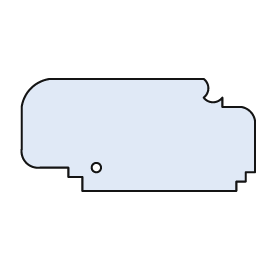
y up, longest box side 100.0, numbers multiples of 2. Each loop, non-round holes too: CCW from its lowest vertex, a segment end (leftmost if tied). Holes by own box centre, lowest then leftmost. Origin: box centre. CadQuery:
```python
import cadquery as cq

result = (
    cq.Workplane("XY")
    .moveTo(-24.0, -24.0)
    .lineTo(42.0, -24.0)
    .lineTo(42.0, -20.0)
    .lineTo(46.0, -20.0)
    .lineTo(46.0, -16.0)
    .lineTo(50.0, -16.0)
    .lineTo(50.0, 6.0)
    .threePointArc((48.0, 10.0), (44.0, 12.0))
    .lineTo(36.0, 12.0)
    .lineTo(36.0, 16.0)
    .threePointArc((32.0, 14.0), (28.0, 16.0))
    .threePointArc((30.0, 20.0), (28.0, 24.0))
    .lineTo(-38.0, 24.0)
    .threePointArc((-46.0, 20.0), (-50.0, 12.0))
    .lineTo(-50.0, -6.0)
    .threePointArc((-48.0, -12.0), (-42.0, -14.0))
    .lineTo(-30.0, -14.0)
    .lineTo(-30.0, -18.0)
    .lineTo(-24.0, -18.0)
    .close()
    .moveTo(-18.0, -14.0)
    .circle(2.0)
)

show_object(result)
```